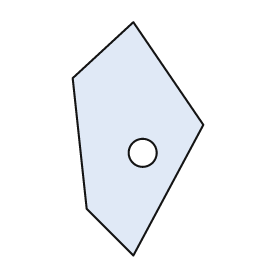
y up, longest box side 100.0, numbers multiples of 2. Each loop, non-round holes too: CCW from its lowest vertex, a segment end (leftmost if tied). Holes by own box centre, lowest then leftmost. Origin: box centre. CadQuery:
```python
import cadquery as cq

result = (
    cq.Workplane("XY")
    .moveTo(-2.0, -50.0)
    .lineTo(28.0, 6.0)
    .lineTo(-2.0, 50.0)
    .lineTo(-28.0, 26.0)
    .lineTo(-22.0, -30.0)
    .close()
    .moveTo(2.0, -6.0)
    .circle(6.0)
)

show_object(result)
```